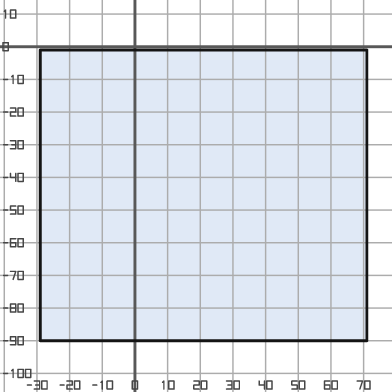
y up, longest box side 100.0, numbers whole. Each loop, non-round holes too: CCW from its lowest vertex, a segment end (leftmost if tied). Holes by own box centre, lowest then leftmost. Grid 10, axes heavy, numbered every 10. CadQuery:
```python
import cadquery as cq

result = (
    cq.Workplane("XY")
    .moveTo(-29.0, -90.0)
    .lineTo(71.0, -90.0)
    .lineTo(71.0, -1.0)
    .lineTo(-29.0, -1.0)
    .close()
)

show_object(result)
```